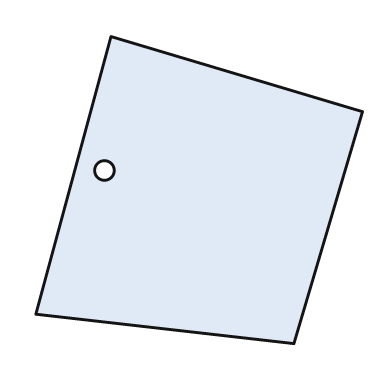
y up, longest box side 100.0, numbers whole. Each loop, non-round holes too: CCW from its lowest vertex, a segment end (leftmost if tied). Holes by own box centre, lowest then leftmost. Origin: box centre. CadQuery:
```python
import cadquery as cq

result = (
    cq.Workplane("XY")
    .moveTo(29.0, -47.0)
    .lineTo(50.0, 24.0)
    .lineTo(-27.0, 47.0)
    .lineTo(-50.0, -38.0)
    .close()
    .moveTo(-29.0, 6.0)
    .circle(3.0)
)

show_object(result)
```